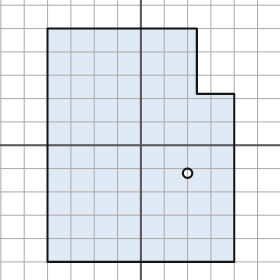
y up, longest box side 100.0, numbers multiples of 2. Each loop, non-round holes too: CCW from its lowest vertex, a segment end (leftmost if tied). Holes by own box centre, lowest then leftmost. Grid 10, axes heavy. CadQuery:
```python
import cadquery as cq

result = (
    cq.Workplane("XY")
    .moveTo(-40.0, -50.0)
    .lineTo(40.0, -50.0)
    .lineTo(40.0, 22.0)
    .lineTo(24.0, 22.0)
    .lineTo(24.0, 50.0)
    .lineTo(-40.0, 50.0)
    .close()
    .moveTo(20.0, -12.0)
    .circle(2.0)
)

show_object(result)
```